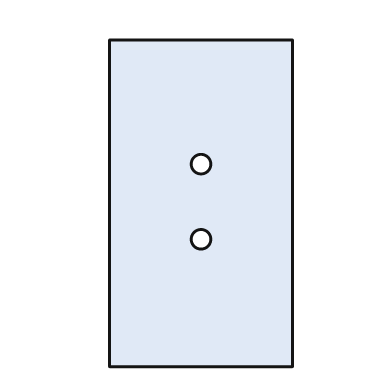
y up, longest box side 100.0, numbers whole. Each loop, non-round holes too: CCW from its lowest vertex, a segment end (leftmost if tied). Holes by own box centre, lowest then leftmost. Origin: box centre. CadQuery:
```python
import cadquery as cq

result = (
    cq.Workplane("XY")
    .moveTo(-28.0, -50.0)
    .lineTo(28.0, -50.0)
    .lineTo(28.0, 50.0)
    .lineTo(-28.0, 50.0)
    .close()
    .moveTo(0.0, -11.0)
    .circle(3.0)
    .moveTo(0.0, 12.0)
    .circle(3.0)
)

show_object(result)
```